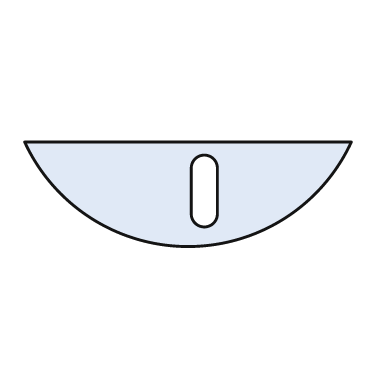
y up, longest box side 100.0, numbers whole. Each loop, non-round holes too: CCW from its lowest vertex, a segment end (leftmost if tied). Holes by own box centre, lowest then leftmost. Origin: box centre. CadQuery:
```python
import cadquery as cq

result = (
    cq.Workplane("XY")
    .moveTo(-50.0, 16.0)
    .threePointArc((0.0, -16.0), (50.0, 16.0))
    .close()
    .moveTo(1.0, -6.0)
    .threePointArc((5.0, -10.0), (9.0, -6.0))
    .lineTo(9.0, 8.0)
    .threePointArc((5.0, 12.0), (1.0, 8.0))
    .close()
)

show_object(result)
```